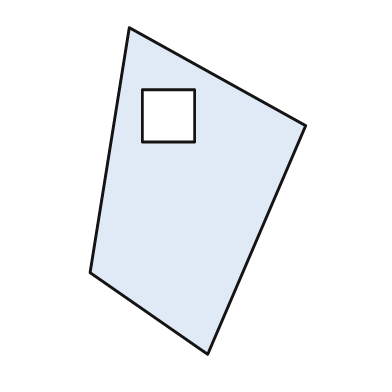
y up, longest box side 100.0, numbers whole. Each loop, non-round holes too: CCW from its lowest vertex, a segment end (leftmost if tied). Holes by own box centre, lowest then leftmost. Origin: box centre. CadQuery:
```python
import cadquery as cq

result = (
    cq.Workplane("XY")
    .moveTo(3.0, -50.0)
    .lineTo(33.0, 20.0)
    .lineTo(-21.0, 50.0)
    .lineTo(-33.0, -25.0)
    .close()
    .moveTo(-17.0, 15.0)
    .lineTo(-1.0, 15.0)
    .lineTo(-1.0, 31.0)
    .lineTo(-17.0, 31.0)
    .close()
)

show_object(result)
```